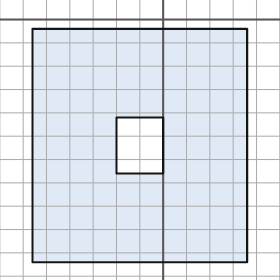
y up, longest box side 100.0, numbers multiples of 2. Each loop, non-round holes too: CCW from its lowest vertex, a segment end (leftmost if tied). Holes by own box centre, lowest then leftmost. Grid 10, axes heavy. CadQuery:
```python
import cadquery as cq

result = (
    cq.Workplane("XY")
    .moveTo(-56.0, -104.0)
    .lineTo(36.0, -104.0)
    .lineTo(36.0, -4.0)
    .lineTo(-56.0, -4.0)
    .close()
    .moveTo(-20.0, -66.0)
    .lineTo(0.0, -66.0)
    .lineTo(0.0, -42.0)
    .lineTo(-20.0, -42.0)
    .close()
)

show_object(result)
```